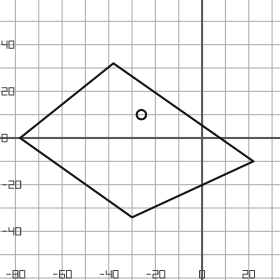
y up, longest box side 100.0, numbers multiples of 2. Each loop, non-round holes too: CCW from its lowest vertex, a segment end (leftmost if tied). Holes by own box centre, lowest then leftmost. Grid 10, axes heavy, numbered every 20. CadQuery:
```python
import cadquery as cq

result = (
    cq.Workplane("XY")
    .moveTo(-30.0, -34.0)
    .lineTo(22.0, -10.0)
    .lineTo(-38.0, 32.0)
    .lineTo(-78.0, 0.0)
    .close()
    .moveTo(-26.0, 10.0)
    .circle(2.0)
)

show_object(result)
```